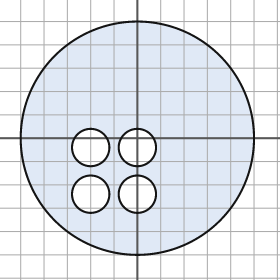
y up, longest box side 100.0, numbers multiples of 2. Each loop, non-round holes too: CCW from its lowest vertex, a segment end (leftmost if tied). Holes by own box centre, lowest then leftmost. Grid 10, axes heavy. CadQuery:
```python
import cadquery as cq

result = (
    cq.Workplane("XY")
    .moveTo(0.0, 0.0)
    .circle(50.0)
    .moveTo(-20.0, -24.0)
    .circle(8.0)
    .moveTo(0.0, -24.0)
    .circle(8.0)
    .moveTo(-20.0, -4.0)
    .circle(8.0)
    .moveTo(0.0, -4.0)
    .circle(8.0)
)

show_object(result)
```